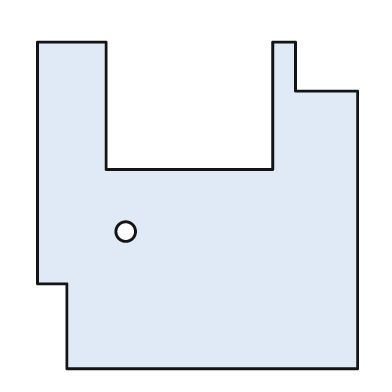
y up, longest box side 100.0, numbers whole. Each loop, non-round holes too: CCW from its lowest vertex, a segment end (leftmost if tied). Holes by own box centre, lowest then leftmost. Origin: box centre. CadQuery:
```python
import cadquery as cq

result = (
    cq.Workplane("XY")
    .moveTo(-40.0, -50.0)
    .lineTo(49.0, -50.0)
    .lineTo(49.0, 35.0)
    .lineTo(30.0, 35.0)
    .lineTo(30.0, 50.0)
    .lineTo(23.0, 50.0)
    .lineTo(23.0, 11.0)
    .lineTo(-28.0, 11.0)
    .lineTo(-28.0, 50.0)
    .lineTo(-49.0, 50.0)
    .lineTo(-49.0, -24.0)
    .lineTo(-40.0, -24.0)
    .close()
    .moveTo(-22.0, -8.0)
    .circle(3.0)
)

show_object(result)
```